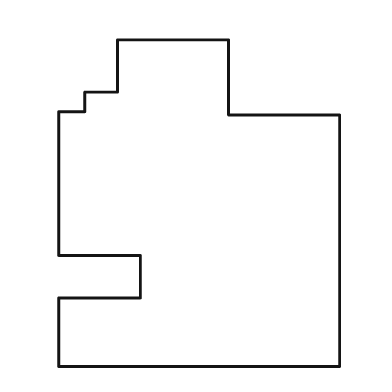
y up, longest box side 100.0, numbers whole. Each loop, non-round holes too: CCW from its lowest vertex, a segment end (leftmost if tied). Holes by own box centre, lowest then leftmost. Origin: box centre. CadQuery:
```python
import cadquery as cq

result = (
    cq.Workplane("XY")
    .moveTo(-43.0, -50.0)
    .lineTo(43.0, -50.0)
    .lineTo(43.0, 27.0)
    .lineTo(9.0, 27.0)
    .lineTo(9.0, 50.0)
    .lineTo(-25.0, 50.0)
    .lineTo(-25.0, 34.0)
    .lineTo(-35.0, 34.0)
    .lineTo(-35.0, 28.0)
    .lineTo(-43.0, 28.0)
    .lineTo(-43.0, -16.0)
    .lineTo(-18.0, -16.0)
    .lineTo(-18.0, -29.0)
    .lineTo(-43.0, -29.0)
    .close()
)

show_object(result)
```